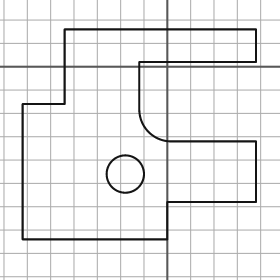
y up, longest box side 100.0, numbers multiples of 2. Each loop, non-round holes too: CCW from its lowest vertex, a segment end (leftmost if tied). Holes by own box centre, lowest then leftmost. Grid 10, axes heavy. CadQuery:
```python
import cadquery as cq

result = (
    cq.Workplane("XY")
    .moveTo(-62.0, -74.0)
    .lineTo(0.0, -74.0)
    .lineTo(0.0, -58.0)
    .lineTo(38.0, -58.0)
    .lineTo(38.0, -32.0)
    .lineTo(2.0, -32.0)
    .threePointArc((-8.0, -28.0), (-12.0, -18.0))
    .lineTo(-12.0, 2.0)
    .lineTo(38.0, 2.0)
    .lineTo(38.0, 16.0)
    .lineTo(-44.0, 16.0)
    .lineTo(-44.0, -16.0)
    .lineTo(-62.0, -16.0)
    .close()
    .moveTo(-18.0, -46.0)
    .circle(8.0)
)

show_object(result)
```